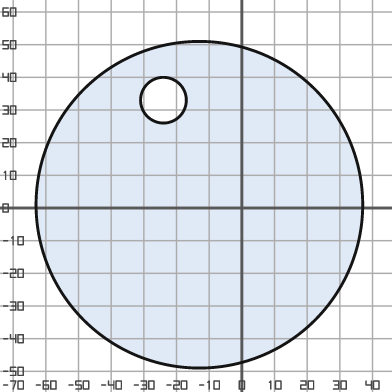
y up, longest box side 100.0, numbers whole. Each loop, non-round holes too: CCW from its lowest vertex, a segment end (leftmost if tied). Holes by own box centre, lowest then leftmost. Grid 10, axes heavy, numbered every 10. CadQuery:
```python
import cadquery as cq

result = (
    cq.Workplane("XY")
    .moveTo(-13.0, 1.0)
    .circle(50.0)
    .moveTo(-24.0, 33.0)
    .circle(7.0)
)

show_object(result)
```